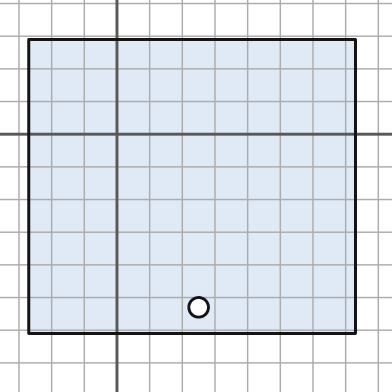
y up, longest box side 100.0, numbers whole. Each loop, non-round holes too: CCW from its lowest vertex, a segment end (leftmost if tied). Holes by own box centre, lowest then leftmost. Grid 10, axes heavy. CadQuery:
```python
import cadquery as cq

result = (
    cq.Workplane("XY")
    .moveTo(-27.0, -61.0)
    .lineTo(73.0, -61.0)
    .lineTo(73.0, 29.0)
    .lineTo(-27.0, 29.0)
    .close()
    .moveTo(25.0, -53.0)
    .circle(3.0)
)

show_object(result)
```